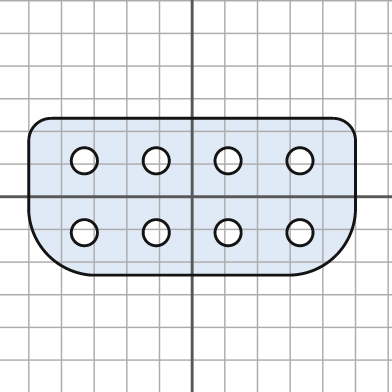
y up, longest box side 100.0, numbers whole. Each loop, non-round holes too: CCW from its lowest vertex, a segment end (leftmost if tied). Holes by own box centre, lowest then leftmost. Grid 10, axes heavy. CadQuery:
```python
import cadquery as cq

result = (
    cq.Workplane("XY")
    .moveTo(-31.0, -24.0)
    .lineTo(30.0, -24.0)
    .threePointArc((44.0, -18.0), (50.0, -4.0))
    .lineTo(50.0, 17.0)
    .threePointArc((48.0, 22.0), (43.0, 24.0))
    .lineTo(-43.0, 24.0)
    .threePointArc((-48.0, 22.0), (-50.0, 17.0))
    .lineTo(-50.0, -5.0)
    .threePointArc((-44.0, -18.0), (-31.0, -24.0))
    .close()
    .moveTo(-33.0, -11.0)
    .circle(4.0)
    .moveTo(-11.0, -11.0)
    .circle(4.0)
    .moveTo(11.0, -11.0)
    .circle(4.0)
    .moveTo(33.0, -11.0)
    .circle(4.0)
    .moveTo(-33.0, 11.0)
    .circle(4.0)
    .moveTo(-11.0, 11.0)
    .circle(4.0)
    .moveTo(11.0, 11.0)
    .circle(4.0)
    .moveTo(33.0, 11.0)
    .circle(4.0)
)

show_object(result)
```